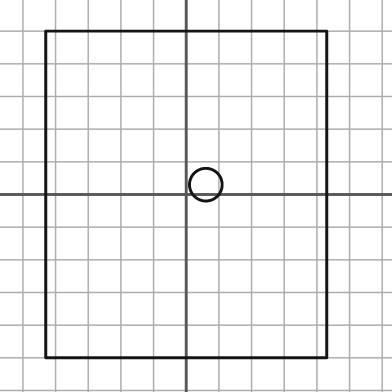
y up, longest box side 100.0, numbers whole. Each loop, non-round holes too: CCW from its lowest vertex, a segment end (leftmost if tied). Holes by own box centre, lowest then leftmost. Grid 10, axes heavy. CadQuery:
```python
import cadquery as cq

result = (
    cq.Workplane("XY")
    .moveTo(-43.0, -50.0)
    .lineTo(43.0, -50.0)
    .lineTo(43.0, 50.0)
    .lineTo(-43.0, 50.0)
    .close()
    .moveTo(6.0, 3.0)
    .circle(5.0)
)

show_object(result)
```